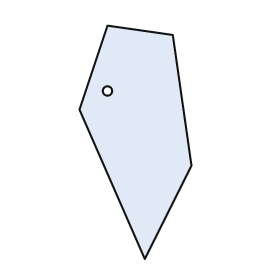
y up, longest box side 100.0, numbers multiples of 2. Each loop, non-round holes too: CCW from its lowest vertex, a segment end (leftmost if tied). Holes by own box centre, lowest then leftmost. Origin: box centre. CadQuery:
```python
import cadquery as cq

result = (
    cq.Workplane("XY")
    .moveTo(4.0, -50.0)
    .lineTo(24.0, -10.0)
    .lineTo(16.0, 46.0)
    .lineTo(-12.0, 50.0)
    .lineTo(-24.0, 14.0)
    .close()
    .moveTo(-12.0, 22.0)
    .circle(2.0)
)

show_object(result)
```